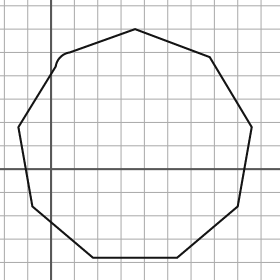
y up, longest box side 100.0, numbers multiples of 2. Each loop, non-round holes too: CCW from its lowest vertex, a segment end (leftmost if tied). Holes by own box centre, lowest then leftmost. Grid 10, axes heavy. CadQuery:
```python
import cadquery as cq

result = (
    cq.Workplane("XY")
    .moveTo(18.0, -38.0)
    .lineTo(54.0, -38.0)
    .lineTo(80.0, -16.0)
    .lineTo(86.0, 18.0)
    .lineTo(68.0, 48.0)
    .lineTo(36.0, 60.0)
    .lineTo(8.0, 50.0)
    .threePointArc((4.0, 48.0), (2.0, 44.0))
    .lineTo(-14.0, 18.0)
    .lineTo(-8.0, -16.0)
    .close()
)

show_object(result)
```